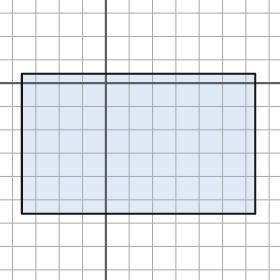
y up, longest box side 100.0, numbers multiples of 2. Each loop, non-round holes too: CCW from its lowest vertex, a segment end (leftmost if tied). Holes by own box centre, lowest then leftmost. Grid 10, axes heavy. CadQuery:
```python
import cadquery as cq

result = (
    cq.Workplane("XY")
    .moveTo(-36.0, -56.0)
    .lineTo(64.0, -56.0)
    .lineTo(64.0, 4.0)
    .lineTo(-36.0, 4.0)
    .close()
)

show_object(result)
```